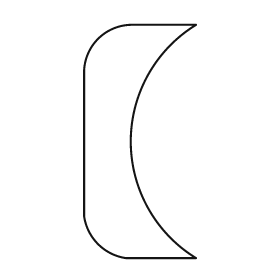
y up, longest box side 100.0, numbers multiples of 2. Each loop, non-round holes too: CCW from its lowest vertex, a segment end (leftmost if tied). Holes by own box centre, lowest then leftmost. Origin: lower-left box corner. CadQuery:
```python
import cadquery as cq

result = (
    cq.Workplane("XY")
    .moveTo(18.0, 0.0)
    .lineTo(48.0, 0.0)
    .threePointArc((20.0, 50.0), (48.0, 100.0))
    .lineTo(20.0, 100.0)
    .threePointArc((6.0, 94.0), (0.0, 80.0))
    .lineTo(0.0, 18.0)
    .threePointArc((6.0, 6.0), (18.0, 0.0))
    .close()
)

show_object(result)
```